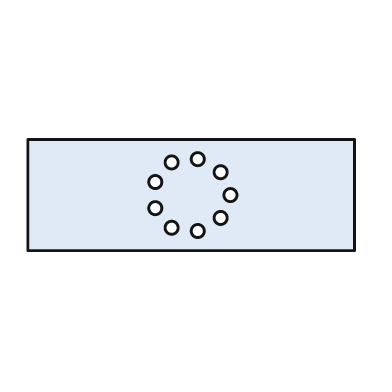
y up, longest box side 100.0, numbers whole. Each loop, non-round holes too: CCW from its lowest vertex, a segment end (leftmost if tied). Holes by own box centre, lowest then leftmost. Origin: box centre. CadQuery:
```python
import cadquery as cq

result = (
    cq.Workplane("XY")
    .moveTo(-50.0, -17.0)
    .lineTo(50.0, -17.0)
    .lineTo(50.0, 17.0)
    .lineTo(-50.0, 17.0)
    .close()
    .moveTo(2.0, -11.0)
    .circle(2.0)
    .moveTo(-6.0, -10.0)
    .circle(2.0)
    .moveTo(9.0, -7.0)
    .circle(2.0)
    .moveTo(-11.0, -4.0)
    .circle(2.0)
    .moveTo(12.0, 0.0)
    .circle(2.0)
    .moveTo(-11.0, 4.0)
    .circle(2.0)
    .moveTo(9.0, 7.0)
    .circle(2.0)
    .moveTo(-6.0, 10.0)
    .circle(2.0)
    .moveTo(2.0, 11.0)
    .circle(2.0)
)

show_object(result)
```